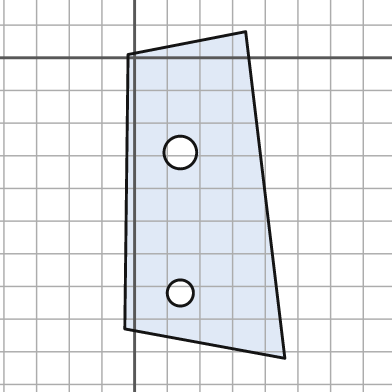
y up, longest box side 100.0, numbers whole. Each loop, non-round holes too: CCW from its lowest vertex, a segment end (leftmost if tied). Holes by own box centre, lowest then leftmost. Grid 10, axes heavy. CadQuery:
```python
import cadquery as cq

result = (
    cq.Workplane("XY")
    .moveTo(46.0, -92.0)
    .lineTo(34.0, 8.0)
    .lineTo(-2.0, 1.0)
    .lineTo(-3.0, -83.0)
    .close()
    .moveTo(14.0, -72.0)
    .circle(4.0)
    .moveTo(14.0, -29.0)
    .circle(5.0)
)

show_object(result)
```